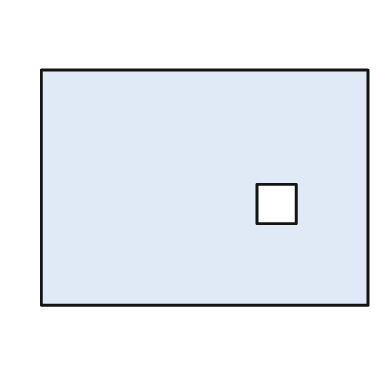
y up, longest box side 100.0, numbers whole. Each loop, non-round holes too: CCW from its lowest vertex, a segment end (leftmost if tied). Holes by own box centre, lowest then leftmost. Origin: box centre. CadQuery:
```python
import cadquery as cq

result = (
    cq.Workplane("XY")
    .moveTo(-50.0, -36.0)
    .lineTo(50.0, -36.0)
    .lineTo(50.0, 36.0)
    .lineTo(-50.0, 36.0)
    .close()
    .moveTo(16.0, -11.0)
    .lineTo(28.0, -11.0)
    .lineTo(28.0, 1.0)
    .lineTo(16.0, 1.0)
    .close()
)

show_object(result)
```